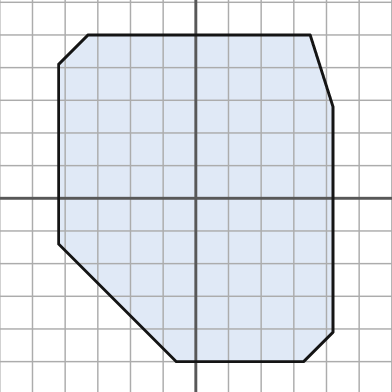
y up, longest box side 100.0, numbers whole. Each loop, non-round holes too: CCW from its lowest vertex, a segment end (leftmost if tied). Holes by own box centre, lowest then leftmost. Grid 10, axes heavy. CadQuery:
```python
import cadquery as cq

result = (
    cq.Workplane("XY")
    .moveTo(-6.0, -50.0)
    .lineTo(33.0, -50.0)
    .lineTo(42.0, -41.0)
    .lineTo(42.0, 28.0)
    .lineTo(35.0, 50.0)
    .lineTo(-33.0, 50.0)
    .lineTo(-42.0, 41.0)
    .lineTo(-42.0, -14.0)
    .close()
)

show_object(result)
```